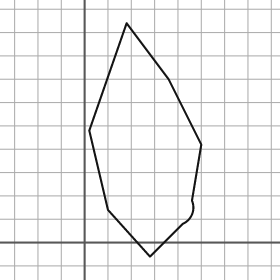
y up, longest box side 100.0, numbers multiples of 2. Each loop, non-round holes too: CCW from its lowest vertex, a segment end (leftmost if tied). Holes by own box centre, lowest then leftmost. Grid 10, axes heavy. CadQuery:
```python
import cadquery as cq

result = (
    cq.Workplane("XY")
    .moveTo(28.0, -6.0)
    .lineTo(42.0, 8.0)
    .threePointArc((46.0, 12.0), (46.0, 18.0))
    .lineTo(50.0, 42.0)
    .lineTo(36.0, 70.0)
    .lineTo(18.0, 94.0)
    .lineTo(2.0, 48.0)
    .lineTo(10.0, 14.0)
    .close()
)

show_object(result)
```